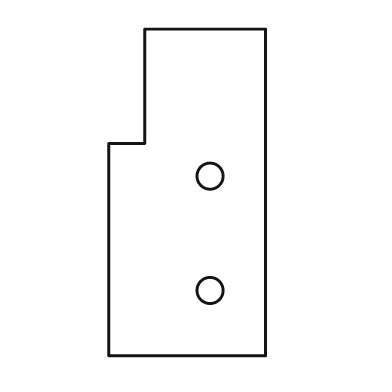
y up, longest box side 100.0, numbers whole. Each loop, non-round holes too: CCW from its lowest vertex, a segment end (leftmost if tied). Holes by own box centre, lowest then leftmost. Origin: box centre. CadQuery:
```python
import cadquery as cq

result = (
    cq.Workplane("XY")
    .moveTo(-24.0, -50.0)
    .lineTo(24.0, -50.0)
    .lineTo(24.0, 50.0)
    .lineTo(-13.0, 50.0)
    .lineTo(-13.0, 15.0)
    .lineTo(-24.0, 15.0)
    .close()
    .moveTo(7.0, -30.0)
    .circle(4.0)
    .moveTo(7.0, 5.0)
    .circle(4.0)
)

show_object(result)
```